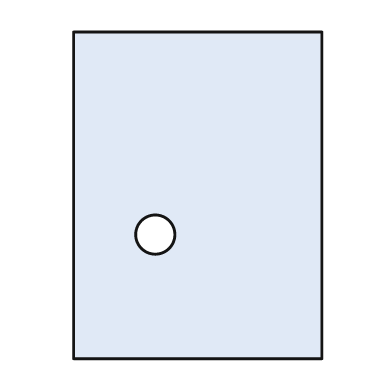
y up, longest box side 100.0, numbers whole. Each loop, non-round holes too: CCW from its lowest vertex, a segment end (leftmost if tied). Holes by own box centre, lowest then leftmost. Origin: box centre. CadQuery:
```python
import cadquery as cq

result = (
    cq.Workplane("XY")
    .moveTo(-38.0, -50.0)
    .lineTo(38.0, -50.0)
    .lineTo(38.0, 50.0)
    .lineTo(-38.0, 50.0)
    .close()
    .moveTo(-13.0, -12.0)
    .circle(6.0)
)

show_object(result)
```